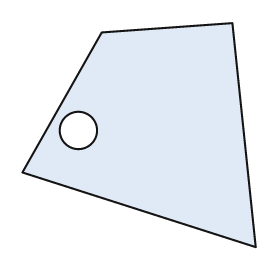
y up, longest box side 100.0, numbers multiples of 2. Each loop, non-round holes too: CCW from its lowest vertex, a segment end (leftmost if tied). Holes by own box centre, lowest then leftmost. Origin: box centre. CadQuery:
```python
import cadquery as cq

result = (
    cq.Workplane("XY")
    .moveTo(50.0, -48.0)
    .lineTo(40.0, 48.0)
    .lineTo(-16.0, 44.0)
    .lineTo(-50.0, -16.0)
    .close()
    .moveTo(-26.0, 2.0)
    .circle(8.0)
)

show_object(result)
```